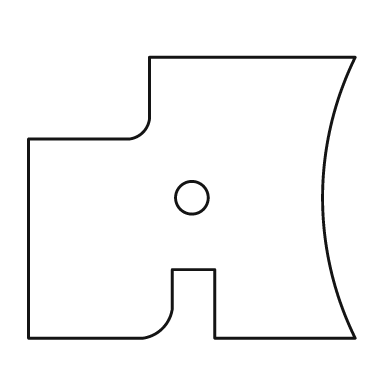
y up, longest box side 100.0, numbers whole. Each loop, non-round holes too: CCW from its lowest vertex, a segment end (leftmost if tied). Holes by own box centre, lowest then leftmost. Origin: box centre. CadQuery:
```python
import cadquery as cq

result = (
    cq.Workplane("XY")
    .moveTo(-50.0, -43.0)
    .lineTo(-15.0, -43.0)
    .threePointArc((-9.0, -40.0), (-6.0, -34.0))
    .lineTo(-6.0, -22.0)
    .lineTo(7.0, -22.0)
    .lineTo(7.0, -43.0)
    .lineTo(50.0, -43.0)
    .threePointArc((40.0, 0.0), (50.0, 43.0))
    .lineTo(-13.0, 43.0)
    .lineTo(-13.0, 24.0)
    .threePointArc((-15.0, 20.0), (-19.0, 18.0))
    .lineTo(-50.0, 18.0)
    .close()
    .moveTo(0.0, 0.0)
    .circle(5.0)
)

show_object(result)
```